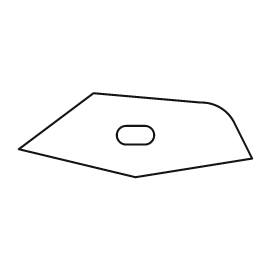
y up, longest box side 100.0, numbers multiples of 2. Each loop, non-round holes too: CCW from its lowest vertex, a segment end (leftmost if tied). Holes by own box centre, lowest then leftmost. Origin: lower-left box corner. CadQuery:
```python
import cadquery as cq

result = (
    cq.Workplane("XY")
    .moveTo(50.0, 0.0)
    .lineTo(100.0, 8.0)
    .lineTo(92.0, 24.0)
    .threePointArc((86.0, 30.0), (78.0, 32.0))
    .lineTo(32.0, 36.0)
    .lineTo(0.0, 12.0)
    .close()
    .moveTo(46.0, 14.0)
    .lineTo(54.0, 14.0)
    .threePointArc((58.0, 18.0), (54.0, 22.0))
    .lineTo(46.0, 22.0)
    .threePointArc((42.0, 18.0), (46.0, 14.0))
    .close()
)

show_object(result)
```